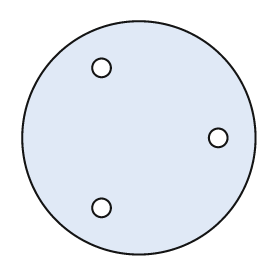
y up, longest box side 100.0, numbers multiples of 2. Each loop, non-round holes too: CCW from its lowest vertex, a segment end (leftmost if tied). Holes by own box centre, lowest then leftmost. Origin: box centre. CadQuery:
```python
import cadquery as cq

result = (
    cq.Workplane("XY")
    .moveTo(0.0, 0.0)
    .circle(50.0)
    .moveTo(-16.0, -30.0)
    .circle(4.0)
    .moveTo(34.0, 0.0)
    .circle(4.0)
    .moveTo(-16.0, 30.0)
    .circle(4.0)
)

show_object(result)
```